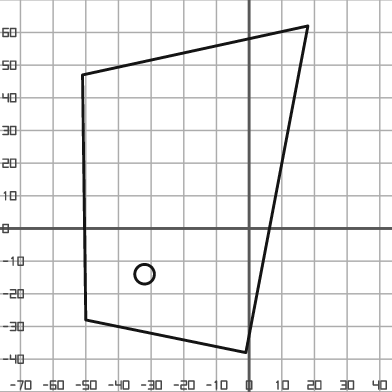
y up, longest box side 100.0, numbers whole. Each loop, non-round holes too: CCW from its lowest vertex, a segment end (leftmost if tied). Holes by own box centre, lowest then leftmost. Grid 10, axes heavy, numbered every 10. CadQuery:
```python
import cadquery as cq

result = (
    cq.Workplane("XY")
    .moveTo(-1.0, -38.0)
    .lineTo(18.0, 62.0)
    .lineTo(-51.0, 47.0)
    .lineTo(-50.0, -28.0)
    .close()
    .moveTo(-32.0, -14.0)
    .circle(3.0)
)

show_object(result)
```